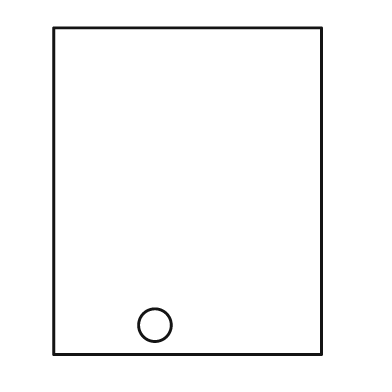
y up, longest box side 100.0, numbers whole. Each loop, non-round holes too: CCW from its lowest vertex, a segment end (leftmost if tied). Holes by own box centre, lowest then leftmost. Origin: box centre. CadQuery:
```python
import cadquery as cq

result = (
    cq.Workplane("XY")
    .moveTo(-41.0, -50.0)
    .lineTo(41.0, -50.0)
    .lineTo(41.0, 50.0)
    .lineTo(-41.0, 50.0)
    .close()
    .moveTo(-10.0, -41.0)
    .circle(5.0)
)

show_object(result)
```